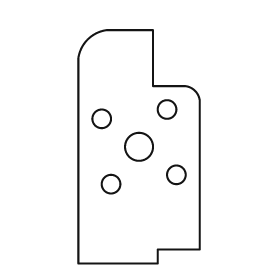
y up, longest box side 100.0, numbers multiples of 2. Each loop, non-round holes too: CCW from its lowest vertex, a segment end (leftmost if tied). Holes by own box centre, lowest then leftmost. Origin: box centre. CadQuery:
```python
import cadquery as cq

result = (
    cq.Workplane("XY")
    .moveTo(-26.0, -50.0)
    .lineTo(8.0, -50.0)
    .lineTo(8.0, -44.0)
    .lineTo(26.0, -44.0)
    .lineTo(26.0, 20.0)
    .threePointArc((24.0, 24.0), (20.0, 26.0))
    .lineTo(6.0, 26.0)
    .lineTo(6.0, 50.0)
    .lineTo(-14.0, 50.0)
    .threePointArc((-22.0, 46.0), (-26.0, 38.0))
    .close()
    .moveTo(-12.0, -16.0)
    .circle(4.0)
    .moveTo(16.0, -12.0)
    .circle(4.0)
    .moveTo(0.0, 0.0)
    .circle(6.0)
    .moveTo(-16.0, 12.0)
    .circle(4.0)
    .moveTo(12.0, 16.0)
    .circle(4.0)
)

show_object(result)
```